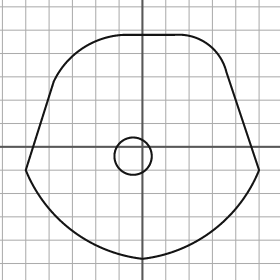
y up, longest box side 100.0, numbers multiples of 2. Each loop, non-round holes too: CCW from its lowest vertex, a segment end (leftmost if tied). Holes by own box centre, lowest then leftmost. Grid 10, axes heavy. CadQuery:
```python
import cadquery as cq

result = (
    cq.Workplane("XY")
    .moveTo(0.0, -48.0)
    .threePointArc((30.0, -36.0), (50.0, -10.0))
    .lineTo(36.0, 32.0)
    .threePointArc((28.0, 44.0), (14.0, 48.0))
    .lineTo(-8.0, 48.0)
    .threePointArc((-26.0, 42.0), (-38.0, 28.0))
    .lineTo(-50.0, -10.0)
    .threePointArc((-30.0, -36.0), (0.0, -48.0))
    .close()
    .moveTo(-4.0, -4.0)
    .circle(8.0)
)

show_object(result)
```